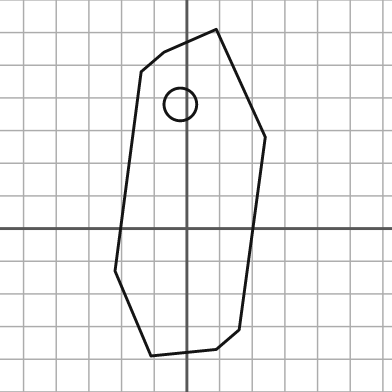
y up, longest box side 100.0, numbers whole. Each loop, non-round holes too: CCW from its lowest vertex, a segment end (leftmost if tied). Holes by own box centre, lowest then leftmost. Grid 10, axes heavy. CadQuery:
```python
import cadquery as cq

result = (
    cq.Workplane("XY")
    .moveTo(-11.0, -39.0)
    .lineTo(9.0, -37.0)
    .lineTo(16.0, -31.0)
    .lineTo(24.0, 28.0)
    .lineTo(9.0, 61.0)
    .lineTo(-7.0, 54.0)
    .lineTo(-14.0, 48.0)
    .lineTo(-22.0, -13.0)
    .close()
    .moveTo(-2.0, 38.0)
    .circle(5.0)
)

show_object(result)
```